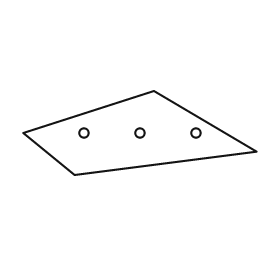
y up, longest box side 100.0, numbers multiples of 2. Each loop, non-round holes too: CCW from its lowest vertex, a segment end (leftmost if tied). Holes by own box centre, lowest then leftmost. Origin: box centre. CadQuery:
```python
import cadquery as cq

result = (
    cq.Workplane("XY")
    .moveTo(-28.0, -18.0)
    .lineTo(50.0, -8.0)
    .lineTo(6.0, 18.0)
    .lineTo(-50.0, 0.0)
    .close()
    .moveTo(-24.0, 0.0)
    .circle(2.0)
    .moveTo(0.0, 0.0)
    .circle(2.0)
    .moveTo(24.0, 0.0)
    .circle(2.0)
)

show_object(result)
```